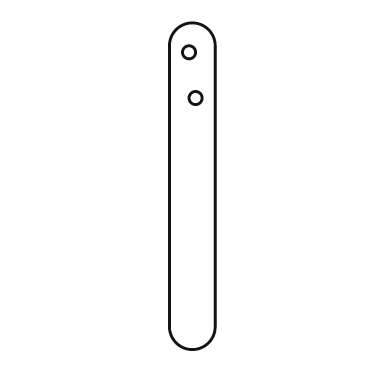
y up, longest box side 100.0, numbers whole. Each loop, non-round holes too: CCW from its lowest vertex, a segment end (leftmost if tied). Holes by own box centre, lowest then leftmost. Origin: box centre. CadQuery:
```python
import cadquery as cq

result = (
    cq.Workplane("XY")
    .moveTo(-7.0, -43.0)
    .threePointArc((0.0, -50.0), (7.0, -43.0))
    .lineTo(7.0, 43.0)
    .threePointArc((0.0, 50.0), (-7.0, 43.0))
    .close()
    .moveTo(1.0, 27.0)
    .circle(2.0)
    .moveTo(-1.0, 41.0)
    .circle(2.0)
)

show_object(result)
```